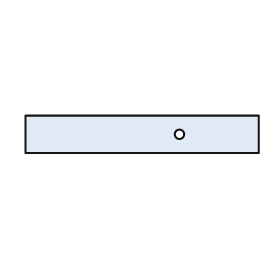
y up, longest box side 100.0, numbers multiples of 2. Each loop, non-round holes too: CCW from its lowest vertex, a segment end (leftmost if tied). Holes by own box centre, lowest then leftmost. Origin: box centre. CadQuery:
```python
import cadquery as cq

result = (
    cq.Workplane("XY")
    .moveTo(-50.0, -8.0)
    .lineTo(50.0, -8.0)
    .lineTo(50.0, 8.0)
    .lineTo(-50.0, 8.0)
    .close()
    .moveTo(16.0, 0.0)
    .circle(2.0)
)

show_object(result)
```